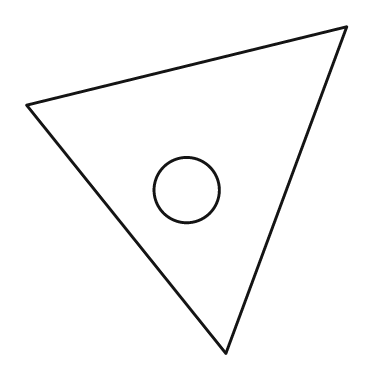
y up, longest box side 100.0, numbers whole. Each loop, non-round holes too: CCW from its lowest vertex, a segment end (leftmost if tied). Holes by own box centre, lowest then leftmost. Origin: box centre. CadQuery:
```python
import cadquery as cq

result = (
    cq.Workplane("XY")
    .moveTo(12.0, -50.0)
    .lineTo(49.0, 50.0)
    .lineTo(-49.0, 26.0)
    .close()
    .moveTo(0.0, 0.0)
    .circle(10.0)
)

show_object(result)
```